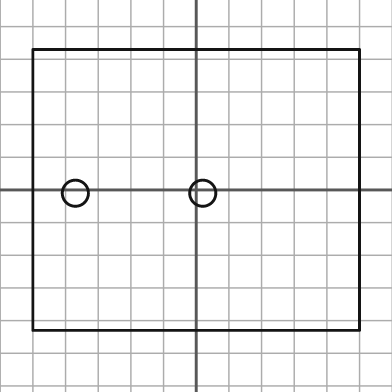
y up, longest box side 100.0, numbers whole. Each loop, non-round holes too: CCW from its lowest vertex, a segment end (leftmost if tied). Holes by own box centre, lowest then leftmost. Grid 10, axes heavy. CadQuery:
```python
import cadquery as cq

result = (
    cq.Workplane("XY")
    .moveTo(-50.0, -43.0)
    .lineTo(50.0, -43.0)
    .lineTo(50.0, 43.0)
    .lineTo(-50.0, 43.0)
    .close()
    .moveTo(-37.0, -1.0)
    .circle(4.0)
    .moveTo(2.0, -1.0)
    .circle(4.0)
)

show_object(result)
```